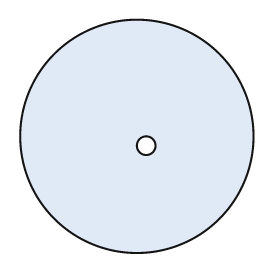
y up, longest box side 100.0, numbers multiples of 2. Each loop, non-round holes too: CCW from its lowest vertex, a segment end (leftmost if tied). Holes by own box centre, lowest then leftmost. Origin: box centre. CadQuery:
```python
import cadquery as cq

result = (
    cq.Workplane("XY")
    .moveTo(0.0, 0.0)
    .circle(50.0)
    .moveTo(4.0, -4.0)
    .circle(4.0)
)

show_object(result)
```